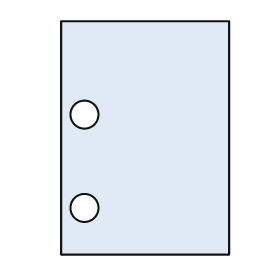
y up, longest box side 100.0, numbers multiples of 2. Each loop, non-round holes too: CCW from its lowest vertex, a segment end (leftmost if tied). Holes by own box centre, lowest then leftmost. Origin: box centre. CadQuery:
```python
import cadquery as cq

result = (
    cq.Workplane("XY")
    .moveTo(-36.0, -50.0)
    .lineTo(36.0, -50.0)
    .lineTo(36.0, 50.0)
    .lineTo(-36.0, 50.0)
    .close()
    .moveTo(-26.0, -30.0)
    .circle(6.0)
    .moveTo(-26.0, 10.0)
    .circle(6.0)
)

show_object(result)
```